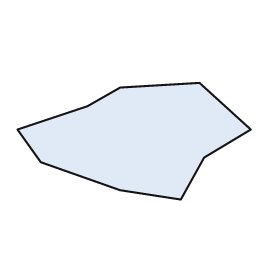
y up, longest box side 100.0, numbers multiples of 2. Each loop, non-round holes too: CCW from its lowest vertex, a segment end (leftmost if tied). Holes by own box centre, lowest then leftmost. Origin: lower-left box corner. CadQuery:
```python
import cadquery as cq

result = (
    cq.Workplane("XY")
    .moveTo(70.0, 0.0)
    .lineTo(80.0, 18.0)
    .lineTo(100.0, 30.0)
    .lineTo(78.0, 50.0)
    .lineTo(44.0, 48.0)
    .lineTo(30.0, 40.0)
    .lineTo(0.0, 30.0)
    .lineTo(10.0, 16.0)
    .lineTo(44.0, 4.0)
    .close()
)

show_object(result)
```